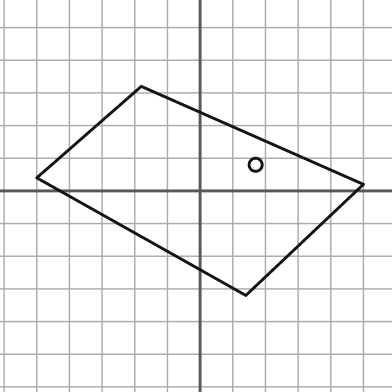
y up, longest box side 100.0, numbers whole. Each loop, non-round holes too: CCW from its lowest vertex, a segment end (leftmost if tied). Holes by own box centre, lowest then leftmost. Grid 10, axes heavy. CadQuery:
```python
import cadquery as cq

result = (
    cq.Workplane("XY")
    .moveTo(14.0, -32.0)
    .lineTo(50.0, 2.0)
    .lineTo(-18.0, 32.0)
    .lineTo(-50.0, 4.0)
    .close()
    .moveTo(17.0, 8.0)
    .circle(2.0)
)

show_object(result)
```